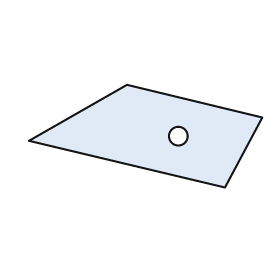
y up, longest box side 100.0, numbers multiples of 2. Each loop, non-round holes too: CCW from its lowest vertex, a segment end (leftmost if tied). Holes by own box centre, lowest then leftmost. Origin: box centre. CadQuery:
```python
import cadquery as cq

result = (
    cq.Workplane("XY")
    .moveTo(34.0, -22.0)
    .lineTo(50.0, 8.0)
    .lineTo(-8.0, 22.0)
    .lineTo(-50.0, -2.0)
    .close()
    .moveTo(14.0, 0.0)
    .circle(4.0)
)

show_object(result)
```